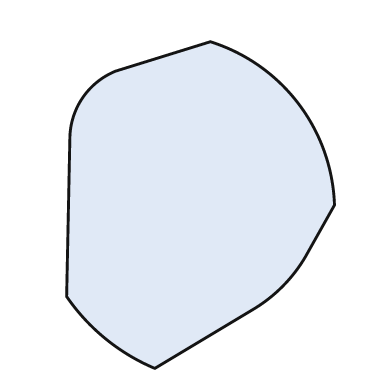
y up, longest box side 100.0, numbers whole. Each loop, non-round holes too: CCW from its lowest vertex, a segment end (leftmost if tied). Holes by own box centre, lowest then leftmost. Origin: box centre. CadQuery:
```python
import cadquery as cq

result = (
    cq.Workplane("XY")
    .moveTo(-14.0, -50.0)
    .lineTo(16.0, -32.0)
    .threePointArc((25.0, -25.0), (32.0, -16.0))
    .lineTo(41.0, 0.0)
    .threePointArc((30.0, 31.0), (3.0, 50.0))
    .lineTo(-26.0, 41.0)
    .threePointArc((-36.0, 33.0), (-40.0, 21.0))
    .lineTo(-41.0, -28.0)
    .threePointArc((-29.0, -41.0), (-14.0, -50.0))
    .close()
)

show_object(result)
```